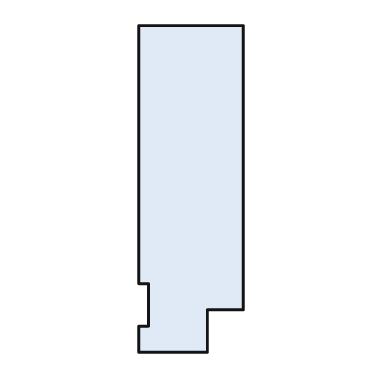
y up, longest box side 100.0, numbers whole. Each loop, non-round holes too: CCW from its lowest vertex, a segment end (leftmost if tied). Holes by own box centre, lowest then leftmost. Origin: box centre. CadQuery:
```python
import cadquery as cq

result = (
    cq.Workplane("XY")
    .moveTo(-16.0, -50.0)
    .lineTo(5.0, -50.0)
    .lineTo(5.0, -37.0)
    .lineTo(16.0, -37.0)
    .lineTo(16.0, 50.0)
    .lineTo(-16.0, 50.0)
    .lineTo(-16.0, -29.0)
    .lineTo(-13.0, -29.0)
    .lineTo(-13.0, -42.0)
    .lineTo(-16.0, -42.0)
    .close()
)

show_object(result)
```